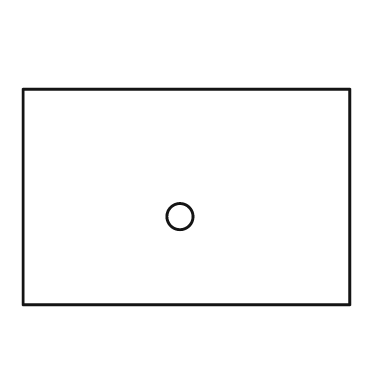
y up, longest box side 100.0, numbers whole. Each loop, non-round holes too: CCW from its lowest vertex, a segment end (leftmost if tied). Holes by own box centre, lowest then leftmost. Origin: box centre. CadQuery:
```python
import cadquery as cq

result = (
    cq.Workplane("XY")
    .moveTo(-50.0, -33.0)
    .lineTo(50.0, -33.0)
    .lineTo(50.0, 33.0)
    .lineTo(-50.0, 33.0)
    .close()
    .moveTo(-2.0, -6.0)
    .circle(4.0)
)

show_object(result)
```